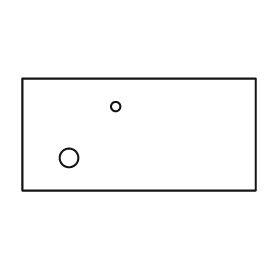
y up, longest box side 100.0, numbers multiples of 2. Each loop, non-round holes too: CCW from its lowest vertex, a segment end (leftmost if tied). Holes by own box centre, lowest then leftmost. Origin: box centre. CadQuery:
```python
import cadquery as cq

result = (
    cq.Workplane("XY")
    .moveTo(-50.0, -24.0)
    .lineTo(50.0, -24.0)
    .lineTo(50.0, 24.0)
    .lineTo(-50.0, 24.0)
    .close()
    .moveTo(-30.0, -10.0)
    .circle(4.0)
    .moveTo(-10.0, 12.0)
    .circle(2.0)
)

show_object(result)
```